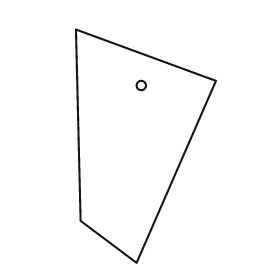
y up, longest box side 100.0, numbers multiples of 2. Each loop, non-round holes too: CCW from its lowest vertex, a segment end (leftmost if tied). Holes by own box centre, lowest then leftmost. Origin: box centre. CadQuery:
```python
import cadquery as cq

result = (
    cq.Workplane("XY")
    .moveTo(-4.0, -50.0)
    .lineTo(30.0, 28.0)
    .lineTo(-30.0, 50.0)
    .lineTo(-28.0, -32.0)
    .close()
    .moveTo(-2.0, 26.0)
    .circle(2.0)
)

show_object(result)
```